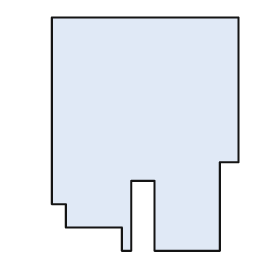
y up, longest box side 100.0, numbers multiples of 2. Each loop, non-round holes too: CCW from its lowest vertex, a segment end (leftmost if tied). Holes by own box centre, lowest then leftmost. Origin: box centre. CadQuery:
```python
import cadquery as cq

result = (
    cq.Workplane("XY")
    .moveTo(-10.0, -50.0)
    .lineTo(-6.0, -50.0)
    .lineTo(-6.0, -20.0)
    .lineTo(4.0, -20.0)
    .lineTo(4.0, -50.0)
    .lineTo(32.0, -50.0)
    .lineTo(32.0, -12.0)
    .lineTo(40.0, -12.0)
    .lineTo(40.0, 50.0)
    .lineTo(-40.0, 50.0)
    .lineTo(-40.0, -30.0)
    .lineTo(-34.0, -30.0)
    .lineTo(-34.0, -40.0)
    .lineTo(-10.0, -40.0)
    .close()
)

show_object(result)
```